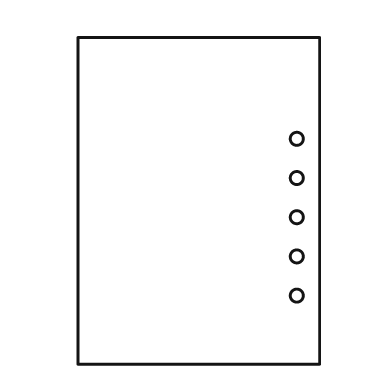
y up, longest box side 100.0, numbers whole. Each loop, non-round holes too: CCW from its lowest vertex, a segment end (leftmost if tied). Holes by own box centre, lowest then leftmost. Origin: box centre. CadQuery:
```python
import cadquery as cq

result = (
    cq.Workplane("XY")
    .moveTo(-37.0, -50.0)
    .lineTo(37.0, -50.0)
    .lineTo(37.0, 50.0)
    .lineTo(-37.0, 50.0)
    .close()
    .moveTo(30.0, -29.0)
    .circle(2.0)
    .moveTo(30.0, -17.0)
    .circle(2.0)
    .moveTo(30.0, -5.0)
    .circle(2.0)
    .moveTo(30.0, 7.0)
    .circle(2.0)
    .moveTo(30.0, 19.0)
    .circle(2.0)
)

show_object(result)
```